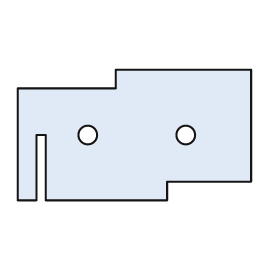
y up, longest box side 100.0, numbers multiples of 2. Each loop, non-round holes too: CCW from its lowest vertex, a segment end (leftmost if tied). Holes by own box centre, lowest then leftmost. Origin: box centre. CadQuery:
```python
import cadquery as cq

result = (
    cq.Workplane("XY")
    .moveTo(-50.0, -28.0)
    .lineTo(-42.0, -28.0)
    .lineTo(-42.0, 0.0)
    .lineTo(-38.0, 0.0)
    .lineTo(-38.0, -28.0)
    .lineTo(14.0, -28.0)
    .lineTo(14.0, -20.0)
    .lineTo(50.0, -20.0)
    .lineTo(50.0, 28.0)
    .lineTo(-8.0, 28.0)
    .lineTo(-8.0, 20.0)
    .lineTo(-50.0, 20.0)
    .close()
    .moveTo(-20.0, 0.0)
    .circle(4.0)
    .moveTo(22.0, 0.0)
    .circle(4.0)
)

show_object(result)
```